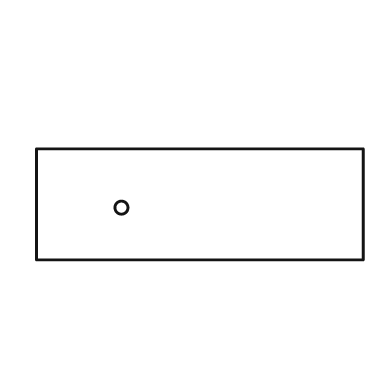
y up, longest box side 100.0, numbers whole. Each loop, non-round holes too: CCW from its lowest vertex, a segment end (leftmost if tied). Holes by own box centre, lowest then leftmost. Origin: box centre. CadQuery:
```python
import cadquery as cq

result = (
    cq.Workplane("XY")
    .moveTo(-50.0, -17.0)
    .lineTo(50.0, -17.0)
    .lineTo(50.0, 17.0)
    .lineTo(-50.0, 17.0)
    .close()
    .moveTo(-24.0, -1.0)
    .circle(2.0)
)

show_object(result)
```